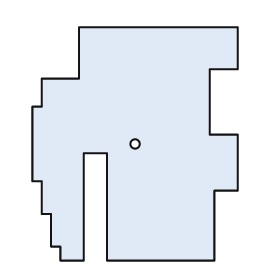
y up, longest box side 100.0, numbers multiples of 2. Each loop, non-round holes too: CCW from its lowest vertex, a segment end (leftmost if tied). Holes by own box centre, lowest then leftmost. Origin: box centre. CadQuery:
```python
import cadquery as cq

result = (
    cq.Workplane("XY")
    .moveTo(-32.0, -50.0)
    .lineTo(-22.0, -50.0)
    .lineTo(-22.0, -4.0)
    .lineTo(-12.0, -4.0)
    .lineTo(-12.0, -50.0)
    .lineTo(34.0, -50.0)
    .lineTo(34.0, -20.0)
    .lineTo(44.0, -20.0)
    .lineTo(44.0, 4.0)
    .lineTo(32.0, 4.0)
    .lineTo(32.0, 32.0)
    .lineTo(44.0, 32.0)
    .lineTo(44.0, 50.0)
    .lineTo(-24.0, 50.0)
    .lineTo(-24.0, 28.0)
    .lineTo(-40.0, 28.0)
    .lineTo(-40.0, 16.0)
    .lineTo(-44.0, 16.0)
    .lineTo(-44.0, -16.0)
    .lineTo(-40.0, -16.0)
    .lineTo(-40.0, -30.0)
    .lineTo(-36.0, -30.0)
    .lineTo(-36.0, -44.0)
    .lineTo(-32.0, -44.0)
    .close()
    .moveTo(0.0, 0.0)
    .circle(2.0)
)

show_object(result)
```